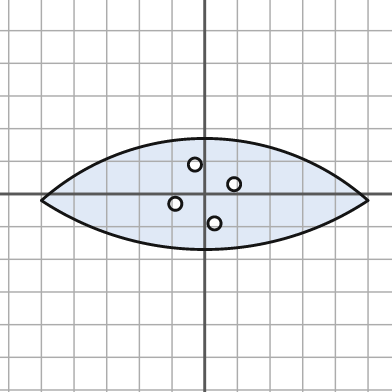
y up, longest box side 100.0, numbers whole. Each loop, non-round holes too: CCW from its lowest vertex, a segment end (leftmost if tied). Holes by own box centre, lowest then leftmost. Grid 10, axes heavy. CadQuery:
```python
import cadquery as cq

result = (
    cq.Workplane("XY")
    .moveTo(-50.0, -2.0)
    .threePointArc((0.0, -17.0), (50.0, -2.0))
    .threePointArc((0.0, 17.0), (-50.0, -2.0))
    .close()
    .moveTo(3.0, -9.0)
    .circle(2.0)
    .moveTo(-9.0, -3.0)
    .circle(2.0)
    .moveTo(9.0, 3.0)
    .circle(2.0)
    .moveTo(-3.0, 9.0)
    .circle(2.0)
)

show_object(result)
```